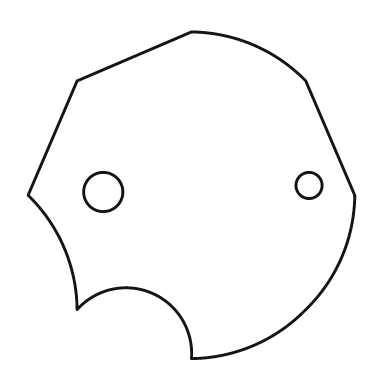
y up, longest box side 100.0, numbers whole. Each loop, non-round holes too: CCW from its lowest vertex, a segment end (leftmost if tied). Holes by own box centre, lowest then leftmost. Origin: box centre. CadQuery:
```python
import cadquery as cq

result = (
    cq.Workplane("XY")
    .moveTo(0.0, -50.0)
    .threePointArc((19.0, -46.0), (35.0, -35.0))
    .threePointArc((46.0, -19.0), (50.0, 0.0))
    .lineTo(35.0, 35.0)
    .threePointArc((19.0, 46.0), (0.0, 50.0))
    .lineTo(-35.0, 35.0)
    .lineTo(-50.0, 0.0)
    .threePointArc((-39.0, -16.0), (-35.0, -35.0))
    .threePointArc((-12.0, -30.0), (0.0, -50.0))
    .close()
    .moveTo(-27.0, 1.0)
    .circle(6.0)
    .moveTo(36.0, 3.0)
    .circle(4.0)
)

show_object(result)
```